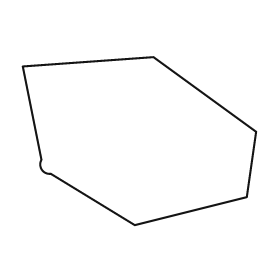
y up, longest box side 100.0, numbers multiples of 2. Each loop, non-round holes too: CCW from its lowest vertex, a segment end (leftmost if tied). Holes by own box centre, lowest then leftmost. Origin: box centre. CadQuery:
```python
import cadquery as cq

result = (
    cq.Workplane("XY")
    .moveTo(-2.0, -36.0)
    .lineTo(46.0, -24.0)
    .lineTo(50.0, 4.0)
    .lineTo(6.0, 36.0)
    .lineTo(-50.0, 32.0)
    .lineTo(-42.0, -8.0)
    .threePointArc((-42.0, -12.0), (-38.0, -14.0))
    .close()
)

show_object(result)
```